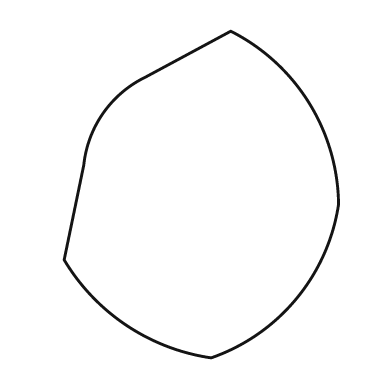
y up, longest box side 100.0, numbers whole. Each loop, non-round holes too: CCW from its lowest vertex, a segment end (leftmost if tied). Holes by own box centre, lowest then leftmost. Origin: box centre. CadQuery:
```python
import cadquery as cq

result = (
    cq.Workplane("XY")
    .moveTo(3.0, -50.0)
    .threePointArc((29.0, -32.0), (42.0, -3.0))
    .threePointArc((33.0, 28.0), (9.0, 50.0))
    .lineTo(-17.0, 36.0)
    .threePointArc((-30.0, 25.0), (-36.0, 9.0))
    .lineTo(-42.0, -20.0)
    .threePointArc((-23.0, -40.0), (3.0, -50.0))
    .close()
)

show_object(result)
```